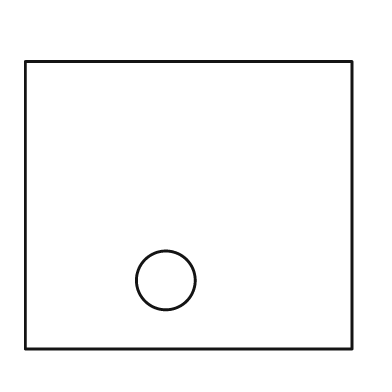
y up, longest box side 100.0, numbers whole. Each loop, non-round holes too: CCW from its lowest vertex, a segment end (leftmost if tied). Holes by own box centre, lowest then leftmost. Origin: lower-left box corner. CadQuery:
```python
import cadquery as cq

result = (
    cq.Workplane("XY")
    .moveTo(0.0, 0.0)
    .lineTo(100.0, 0.0)
    .lineTo(100.0, 88.0)
    .lineTo(0.0, 88.0)
    .close()
    .moveTo(43.0, 21.0)
    .circle(9.0)
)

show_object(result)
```